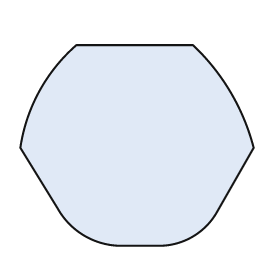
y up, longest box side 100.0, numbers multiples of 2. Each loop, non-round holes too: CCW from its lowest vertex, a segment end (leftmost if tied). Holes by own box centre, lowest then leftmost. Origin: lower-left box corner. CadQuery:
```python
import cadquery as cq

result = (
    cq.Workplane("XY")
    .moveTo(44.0, 0.0)
    .lineTo(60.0, 0.0)
    .threePointArc((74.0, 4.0), (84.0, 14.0))
    .lineTo(100.0, 42.0)
    .threePointArc((90.0, 66.0), (74.0, 86.0))
    .lineTo(24.0, 86.0)
    .threePointArc((8.0, 66.0), (0.0, 42.0))
    .lineTo(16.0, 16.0)
    .threePointArc((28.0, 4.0), (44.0, 0.0))
    .close()
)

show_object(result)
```